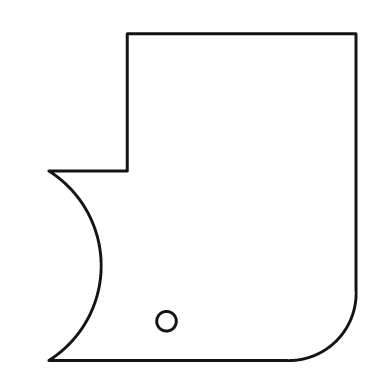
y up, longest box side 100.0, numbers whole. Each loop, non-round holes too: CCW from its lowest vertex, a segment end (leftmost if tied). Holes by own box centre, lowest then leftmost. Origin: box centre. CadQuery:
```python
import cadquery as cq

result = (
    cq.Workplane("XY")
    .moveTo(-47.0, -50.0)
    .lineTo(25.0, -50.0)
    .threePointArc((41.0, -44.0), (47.0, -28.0))
    .lineTo(47.0, 50.0)
    .lineTo(-23.0, 50.0)
    .lineTo(-23.0, 8.0)
    .lineTo(-47.0, 8.0)
    .threePointArc((-31.0, -21.0), (-47.0, -50.0))
    .close()
    .moveTo(-11.0, -38.0)
    .circle(3.0)
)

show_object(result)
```